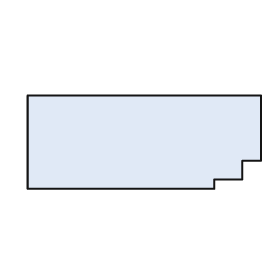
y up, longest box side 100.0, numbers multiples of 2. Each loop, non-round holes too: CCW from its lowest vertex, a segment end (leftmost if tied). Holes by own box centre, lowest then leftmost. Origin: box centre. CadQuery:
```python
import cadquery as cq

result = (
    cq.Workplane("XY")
    .moveTo(-50.0, -20.0)
    .lineTo(30.0, -20.0)
    .lineTo(30.0, -16.0)
    .lineTo(42.0, -16.0)
    .lineTo(42.0, -8.0)
    .lineTo(50.0, -8.0)
    .lineTo(50.0, 20.0)
    .lineTo(-50.0, 20.0)
    .close()
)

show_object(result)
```